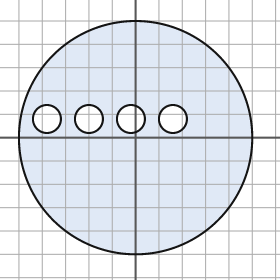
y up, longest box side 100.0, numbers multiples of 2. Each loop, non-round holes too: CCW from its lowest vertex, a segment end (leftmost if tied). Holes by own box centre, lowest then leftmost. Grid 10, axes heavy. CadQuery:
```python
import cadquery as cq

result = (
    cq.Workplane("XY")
    .moveTo(0.0, 0.0)
    .circle(50.0)
    .moveTo(-38.0, 8.0)
    .circle(6.0)
    .moveTo(-20.0, 8.0)
    .circle(6.0)
    .moveTo(-2.0, 8.0)
    .circle(6.0)
    .moveTo(16.0, 8.0)
    .circle(6.0)
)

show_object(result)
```